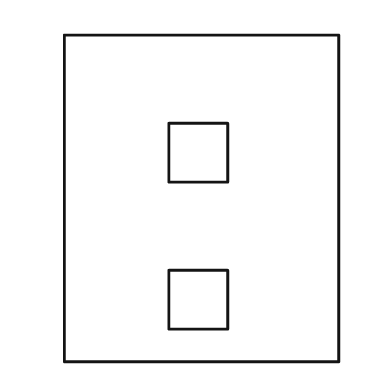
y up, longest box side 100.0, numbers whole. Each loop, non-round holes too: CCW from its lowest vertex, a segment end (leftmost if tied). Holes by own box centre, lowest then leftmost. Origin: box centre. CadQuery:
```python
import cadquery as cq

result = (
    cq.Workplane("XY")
    .moveTo(-42.0, -50.0)
    .lineTo(42.0, -50.0)
    .lineTo(42.0, 50.0)
    .lineTo(-42.0, 50.0)
    .close()
    .moveTo(-10.0, -40.0)
    .lineTo(8.0, -40.0)
    .lineTo(8.0, -22.0)
    .lineTo(-10.0, -22.0)
    .close()
    .moveTo(-10.0, 5.0)
    .lineTo(8.0, 5.0)
    .lineTo(8.0, 23.0)
    .lineTo(-10.0, 23.0)
    .close()
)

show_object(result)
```